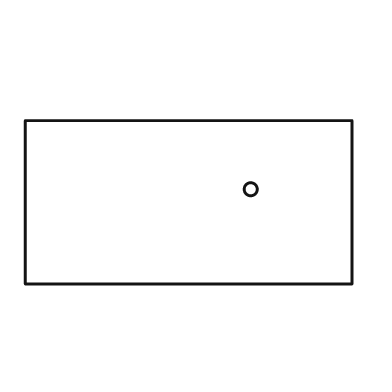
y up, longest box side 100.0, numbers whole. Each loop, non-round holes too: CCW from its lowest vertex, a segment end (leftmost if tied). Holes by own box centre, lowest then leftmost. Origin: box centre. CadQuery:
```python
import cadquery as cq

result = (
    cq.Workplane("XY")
    .moveTo(-50.0, -25.0)
    .lineTo(50.0, -25.0)
    .lineTo(50.0, 25.0)
    .lineTo(-50.0, 25.0)
    .close()
    .moveTo(19.0, 4.0)
    .circle(2.0)
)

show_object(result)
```